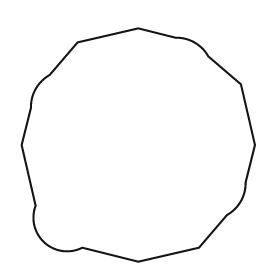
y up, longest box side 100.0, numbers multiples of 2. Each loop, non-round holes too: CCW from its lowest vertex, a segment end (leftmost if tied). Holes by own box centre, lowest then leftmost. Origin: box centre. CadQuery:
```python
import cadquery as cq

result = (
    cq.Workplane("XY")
    .moveTo(0.0, -50.0)
    .lineTo(26.0, -44.0)
    .lineTo(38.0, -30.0)
    .threePointArc((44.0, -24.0), (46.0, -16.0))
    .lineTo(50.0, 0.0)
    .lineTo(44.0, 26.0)
    .lineTo(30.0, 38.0)
    .threePointArc((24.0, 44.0), (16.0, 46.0))
    .lineTo(0.0, 50.0)
    .lineTo(-26.0, 44.0)
    .lineTo(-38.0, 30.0)
    .threePointArc((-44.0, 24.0), (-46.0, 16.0))
    .lineTo(-50.0, 0.0)
    .lineTo(-44.0, -26.0)
    .threePointArc((-40.0, -42.0), (-24.0, -44.0))
    .close()
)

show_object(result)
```